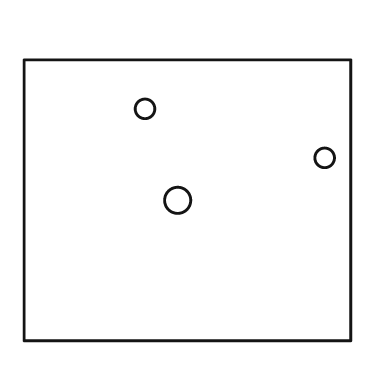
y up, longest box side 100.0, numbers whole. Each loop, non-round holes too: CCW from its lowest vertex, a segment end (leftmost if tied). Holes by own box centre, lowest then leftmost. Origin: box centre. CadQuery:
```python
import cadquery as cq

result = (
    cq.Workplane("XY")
    .moveTo(-50.0, -43.0)
    .lineTo(50.0, -43.0)
    .lineTo(50.0, 43.0)
    .lineTo(-50.0, 43.0)
    .close()
    .moveTo(-3.0, 0.0)
    .circle(4.0)
    .moveTo(42.0, 13.0)
    .circle(3.0)
    .moveTo(-13.0, 28.0)
    .circle(3.0)
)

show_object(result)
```